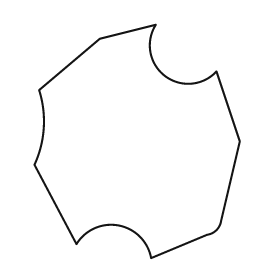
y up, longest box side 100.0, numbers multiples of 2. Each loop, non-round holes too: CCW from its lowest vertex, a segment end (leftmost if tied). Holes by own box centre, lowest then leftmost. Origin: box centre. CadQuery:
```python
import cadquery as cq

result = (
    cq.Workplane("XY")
    .moveTo(6.0, -50.0)
    .lineTo(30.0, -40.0)
    .threePointArc((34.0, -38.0), (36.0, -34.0))
    .lineTo(44.0, 0.0)
    .lineTo(34.0, 30.0)
    .threePointArc((12.0, 28.0), (8.0, 50.0))
    .lineTo(-16.0, 44.0)
    .lineTo(-42.0, 22.0)
    .threePointArc((-40.0, 6.0), (-44.0, -10.0))
    .lineTo(-26.0, -44.0)
    .threePointArc((-8.0, -36.0), (6.0, -50.0))
    .close()
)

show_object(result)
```